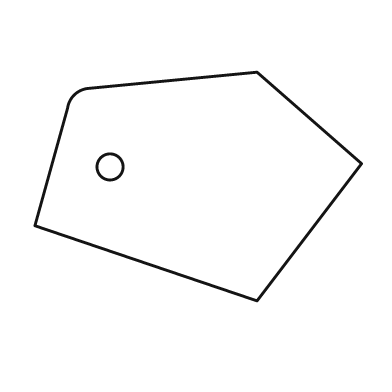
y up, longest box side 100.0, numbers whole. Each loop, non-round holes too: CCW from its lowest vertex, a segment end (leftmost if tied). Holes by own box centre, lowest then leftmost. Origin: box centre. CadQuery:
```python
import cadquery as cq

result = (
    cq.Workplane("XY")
    .moveTo(18.0, -35.0)
    .lineTo(50.0, 7.0)
    .lineTo(18.0, 35.0)
    .lineTo(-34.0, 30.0)
    .threePointArc((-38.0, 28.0), (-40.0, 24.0))
    .lineTo(-50.0, -12.0)
    .close()
    .moveTo(-27.0, 6.0)
    .circle(4.0)
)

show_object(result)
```